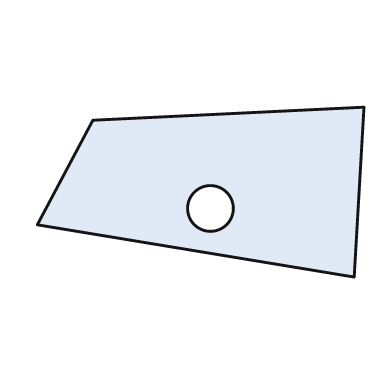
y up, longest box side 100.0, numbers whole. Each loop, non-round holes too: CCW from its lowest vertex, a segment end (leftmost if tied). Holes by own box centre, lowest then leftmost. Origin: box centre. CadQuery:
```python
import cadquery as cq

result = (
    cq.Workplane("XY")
    .moveTo(47.0, -26.0)
    .lineTo(50.0, 26.0)
    .lineTo(-33.0, 22.0)
    .lineTo(-50.0, -10.0)
    .close()
    .moveTo(3.0, -5.0)
    .circle(7.0)
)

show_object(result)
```